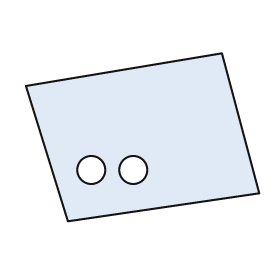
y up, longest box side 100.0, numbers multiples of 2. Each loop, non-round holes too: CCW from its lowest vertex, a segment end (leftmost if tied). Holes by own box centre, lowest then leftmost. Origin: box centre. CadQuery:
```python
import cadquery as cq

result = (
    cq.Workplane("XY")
    .moveTo(-32.0, -36.0)
    .lineTo(50.0, -24.0)
    .lineTo(34.0, 36.0)
    .lineTo(-50.0, 22.0)
    .close()
    .moveTo(-22.0, -14.0)
    .circle(6.0)
    .moveTo(-4.0, -14.0)
    .circle(6.0)
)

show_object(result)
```